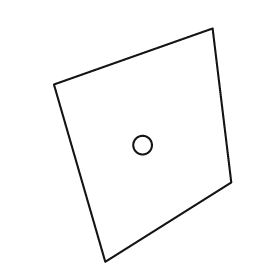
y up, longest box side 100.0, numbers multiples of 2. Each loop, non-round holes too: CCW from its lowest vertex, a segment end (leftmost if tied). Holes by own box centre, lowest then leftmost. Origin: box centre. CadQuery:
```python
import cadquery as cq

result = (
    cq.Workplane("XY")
    .moveTo(-16.0, -50.0)
    .lineTo(38.0, -16.0)
    .lineTo(30.0, 50.0)
    .lineTo(-38.0, 26.0)
    .close()
    .moveTo(0.0, 0.0)
    .circle(4.0)
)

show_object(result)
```